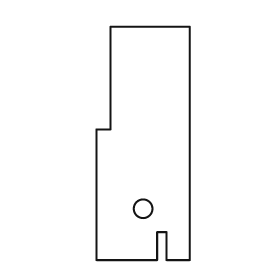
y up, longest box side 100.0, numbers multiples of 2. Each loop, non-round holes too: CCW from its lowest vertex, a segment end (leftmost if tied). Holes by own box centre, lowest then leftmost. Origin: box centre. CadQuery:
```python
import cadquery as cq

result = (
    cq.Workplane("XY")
    .moveTo(-20.0, -50.0)
    .lineTo(6.0, -50.0)
    .lineTo(6.0, -38.0)
    .lineTo(10.0, -38.0)
    .lineTo(10.0, -50.0)
    .lineTo(20.0, -50.0)
    .lineTo(20.0, 50.0)
    .lineTo(-14.0, 50.0)
    .lineTo(-14.0, 6.0)
    .lineTo(-20.0, 6.0)
    .close()
    .moveTo(0.0, -28.0)
    .circle(4.0)
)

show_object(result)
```